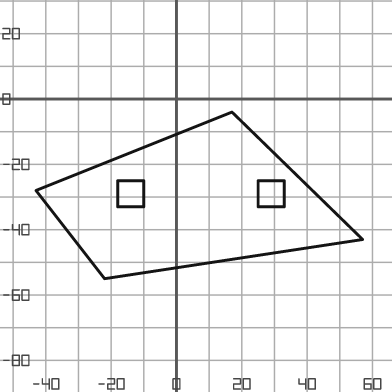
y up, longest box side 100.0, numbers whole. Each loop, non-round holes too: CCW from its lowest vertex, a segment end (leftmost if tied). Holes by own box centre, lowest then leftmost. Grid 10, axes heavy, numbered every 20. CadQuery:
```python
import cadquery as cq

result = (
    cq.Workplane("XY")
    .moveTo(-22.0, -55.0)
    .lineTo(57.0, -43.0)
    .lineTo(17.0, -4.0)
    .lineTo(-43.0, -28.0)
    .close()
    .moveTo(-18.0, -33.0)
    .lineTo(-10.0, -33.0)
    .lineTo(-10.0, -25.0)
    .lineTo(-18.0, -25.0)
    .close()
    .moveTo(25.0, -33.0)
    .lineTo(33.0, -33.0)
    .lineTo(33.0, -25.0)
    .lineTo(25.0, -25.0)
    .close()
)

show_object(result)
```